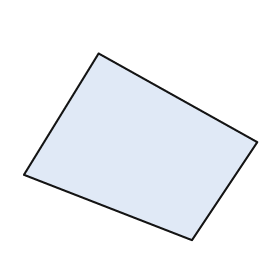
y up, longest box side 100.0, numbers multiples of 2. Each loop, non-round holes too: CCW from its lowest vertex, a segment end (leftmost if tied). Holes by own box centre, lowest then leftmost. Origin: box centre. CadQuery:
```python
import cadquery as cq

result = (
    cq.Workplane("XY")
    .moveTo(22.0, -40.0)
    .lineTo(50.0, 2.0)
    .lineTo(-18.0, 40.0)
    .lineTo(-50.0, -12.0)
    .close()
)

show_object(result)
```